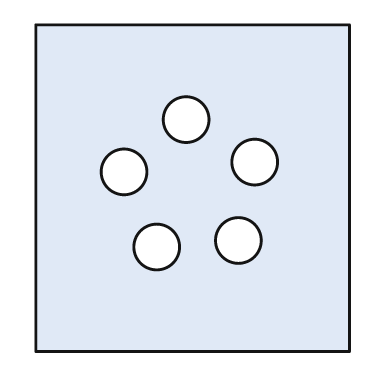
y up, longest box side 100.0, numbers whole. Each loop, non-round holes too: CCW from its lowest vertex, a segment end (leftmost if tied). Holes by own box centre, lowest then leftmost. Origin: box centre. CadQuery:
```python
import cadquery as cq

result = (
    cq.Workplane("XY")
    .moveTo(-48.0, -50.0)
    .lineTo(48.0, -50.0)
    .lineTo(48.0, 50.0)
    .lineTo(-48.0, 50.0)
    .close()
    .moveTo(-11.0, -18.0)
    .circle(7.0)
    .moveTo(14.0, -16.0)
    .circle(7.0)
    .moveTo(-21.0, 5.0)
    .circle(7.0)
    .moveTo(19.0, 8.0)
    .circle(7.0)
    .moveTo(-2.0, 21.0)
    .circle(7.0)
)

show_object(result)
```